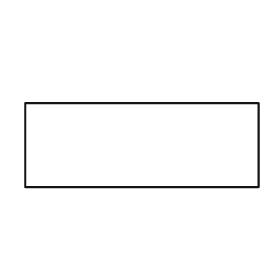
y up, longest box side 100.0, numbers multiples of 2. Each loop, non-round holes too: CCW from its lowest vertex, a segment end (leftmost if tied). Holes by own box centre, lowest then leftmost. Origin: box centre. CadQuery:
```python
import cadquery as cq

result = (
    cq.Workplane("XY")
    .moveTo(-50.0, -18.0)
    .lineTo(50.0, -18.0)
    .lineTo(50.0, 18.0)
    .lineTo(-50.0, 18.0)
    .close()
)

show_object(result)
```